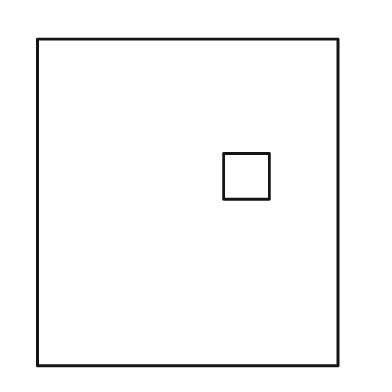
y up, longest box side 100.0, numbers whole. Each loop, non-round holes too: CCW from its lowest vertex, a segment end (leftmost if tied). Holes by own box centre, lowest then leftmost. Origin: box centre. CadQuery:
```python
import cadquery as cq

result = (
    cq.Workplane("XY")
    .moveTo(-46.0, -50.0)
    .lineTo(46.0, -50.0)
    .lineTo(46.0, 50.0)
    .lineTo(-46.0, 50.0)
    .close()
    .moveTo(11.0, 1.0)
    .lineTo(25.0, 1.0)
    .lineTo(25.0, 15.0)
    .lineTo(11.0, 15.0)
    .close()
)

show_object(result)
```